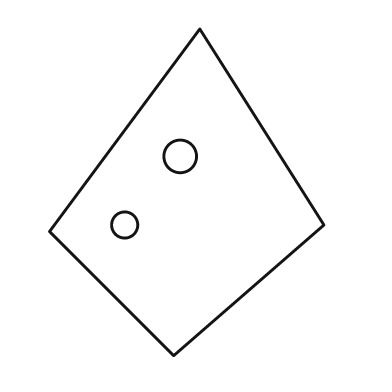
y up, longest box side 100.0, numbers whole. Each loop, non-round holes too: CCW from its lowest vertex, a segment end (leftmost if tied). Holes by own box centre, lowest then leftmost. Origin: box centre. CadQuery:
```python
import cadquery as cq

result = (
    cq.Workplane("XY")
    .moveTo(-4.0, -50.0)
    .lineTo(42.0, -10.0)
    .lineTo(4.0, 50.0)
    .lineTo(-42.0, -12.0)
    .close()
    .moveTo(-19.0, -10.0)
    .circle(4.0)
    .moveTo(-2.0, 11.0)
    .circle(5.0)
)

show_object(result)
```